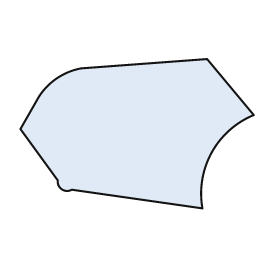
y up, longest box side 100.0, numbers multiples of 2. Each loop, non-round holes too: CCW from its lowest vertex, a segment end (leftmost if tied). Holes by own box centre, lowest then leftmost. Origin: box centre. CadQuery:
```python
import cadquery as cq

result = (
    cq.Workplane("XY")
    .moveTo(28.0, -32.0)
    .threePointArc((32.0, -8.0), (50.0, 8.0))
    .lineTo(30.0, 32.0)
    .lineTo(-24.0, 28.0)
    .threePointArc((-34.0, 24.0), (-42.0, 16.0))
    .lineTo(-50.0, 2.0)
    .lineTo(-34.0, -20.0)
    .threePointArc((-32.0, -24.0), (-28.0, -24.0))
    .close()
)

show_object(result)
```